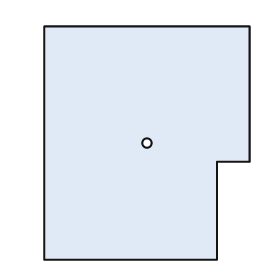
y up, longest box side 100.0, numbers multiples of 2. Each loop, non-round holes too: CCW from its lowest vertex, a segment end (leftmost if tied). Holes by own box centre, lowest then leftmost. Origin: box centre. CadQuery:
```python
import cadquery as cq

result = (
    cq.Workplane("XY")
    .moveTo(-44.0, -50.0)
    .lineTo(30.0, -50.0)
    .lineTo(30.0, -8.0)
    .lineTo(44.0, -8.0)
    .lineTo(44.0, 50.0)
    .lineTo(-44.0, 50.0)
    .close()
    .moveTo(0.0, 0.0)
    .circle(2.0)
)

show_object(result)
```